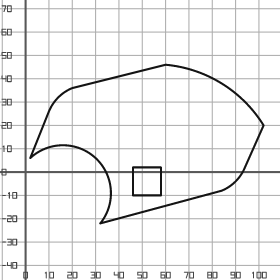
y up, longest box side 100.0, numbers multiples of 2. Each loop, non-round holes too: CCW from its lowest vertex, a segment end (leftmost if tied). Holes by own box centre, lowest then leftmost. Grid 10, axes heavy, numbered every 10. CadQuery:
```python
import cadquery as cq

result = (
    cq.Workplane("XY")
    .moveTo(32.0, -22.0)
    .lineTo(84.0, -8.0)
    .threePointArc((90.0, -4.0), (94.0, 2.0))
    .lineTo(102.0, 20.0)
    .threePointArc((84.0, 38.0), (60.0, 46.0))
    .lineTo(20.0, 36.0)
    .threePointArc((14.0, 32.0), (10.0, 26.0))
    .lineTo(2.0, 6.0)
    .threePointArc((30.0, 6.0), (32.0, -22.0))
    .close()
    .moveTo(46.0, -10.0)
    .lineTo(58.0, -10.0)
    .lineTo(58.0, 2.0)
    .lineTo(46.0, 2.0)
    .close()
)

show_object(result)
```